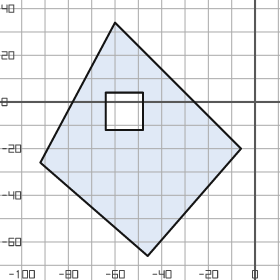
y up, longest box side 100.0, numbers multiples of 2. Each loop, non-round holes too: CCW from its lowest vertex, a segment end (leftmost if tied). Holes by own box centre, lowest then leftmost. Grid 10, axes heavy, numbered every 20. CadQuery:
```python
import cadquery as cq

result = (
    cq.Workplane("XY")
    .moveTo(-46.0, -66.0)
    .lineTo(-6.0, -20.0)
    .lineTo(-60.0, 34.0)
    .lineTo(-92.0, -26.0)
    .close()
    .moveTo(-64.0, -12.0)
    .lineTo(-48.0, -12.0)
    .lineTo(-48.0, 4.0)
    .lineTo(-64.0, 4.0)
    .close()
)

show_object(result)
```